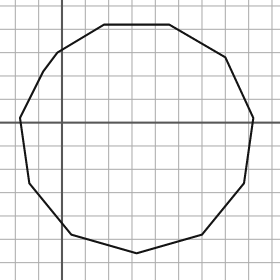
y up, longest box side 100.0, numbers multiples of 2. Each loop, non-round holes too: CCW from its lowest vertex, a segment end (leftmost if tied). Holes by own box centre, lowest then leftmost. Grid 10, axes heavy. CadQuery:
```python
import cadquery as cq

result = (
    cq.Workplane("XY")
    .moveTo(32.0, -56.0)
    .lineTo(60.0, -48.0)
    .lineTo(78.0, -26.0)
    .lineTo(82.0, 2.0)
    .lineTo(70.0, 28.0)
    .lineTo(46.0, 42.0)
    .lineTo(18.0, 42.0)
    .lineTo(-2.0, 30.0)
    .lineTo(-8.0, 22.0)
    .lineTo(-18.0, 2.0)
    .lineTo(-14.0, -26.0)
    .lineTo(4.0, -48.0)
    .close()
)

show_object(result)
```